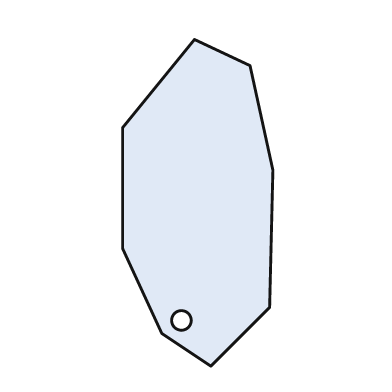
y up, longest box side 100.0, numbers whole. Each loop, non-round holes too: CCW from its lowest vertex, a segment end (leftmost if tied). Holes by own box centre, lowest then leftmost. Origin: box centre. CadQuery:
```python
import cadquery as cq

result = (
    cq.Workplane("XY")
    .moveTo(4.0, -50.0)
    .lineTo(22.0, -32.0)
    .lineTo(23.0, 10.0)
    .lineTo(16.0, 42.0)
    .lineTo(-1.0, 50.0)
    .lineTo(-23.0, 23.0)
    .lineTo(-23.0, -14.0)
    .lineTo(-11.0, -40.0)
    .close()
    .moveTo(-5.0, -36.0)
    .circle(3.0)
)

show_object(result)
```